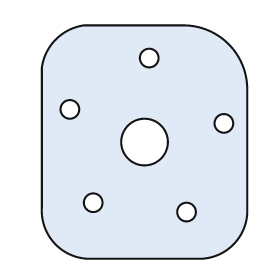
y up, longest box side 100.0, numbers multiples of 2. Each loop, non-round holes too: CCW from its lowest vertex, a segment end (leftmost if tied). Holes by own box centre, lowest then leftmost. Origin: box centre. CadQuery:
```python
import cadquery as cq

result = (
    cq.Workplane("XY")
    .moveTo(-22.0, -50.0)
    .lineTo(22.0, -50.0)
    .threePointArc((38.0, -44.0), (44.0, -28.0))
    .lineTo(44.0, 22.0)
    .threePointArc((36.0, 42.0), (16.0, 50.0))
    .lineTo(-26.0, 50.0)
    .threePointArc((-38.0, 44.0), (-44.0, 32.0))
    .lineTo(-44.0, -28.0)
    .threePointArc((-38.0, -44.0), (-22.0, -50.0))
    .close()
    .moveTo(18.0, -30.0)
    .circle(4.0)
    .moveTo(-22.0, -26.0)
    .circle(4.0)
    .moveTo(0.0, 0.0)
    .circle(10.0)
    .moveTo(34.0, 8.0)
    .circle(4.0)
    .moveTo(-32.0, 14.0)
    .circle(4.0)
    .moveTo(2.0, 36.0)
    .circle(4.0)
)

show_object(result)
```